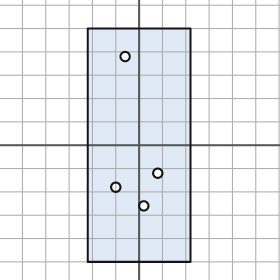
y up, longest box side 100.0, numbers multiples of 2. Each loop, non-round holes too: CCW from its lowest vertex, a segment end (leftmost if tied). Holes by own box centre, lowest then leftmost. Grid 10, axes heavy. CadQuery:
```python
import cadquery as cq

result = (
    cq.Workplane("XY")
    .moveTo(-22.0, -50.0)
    .lineTo(22.0, -50.0)
    .lineTo(22.0, 50.0)
    .lineTo(-22.0, 50.0)
    .close()
    .moveTo(2.0, -26.0)
    .circle(2.0)
    .moveTo(-10.0, -18.0)
    .circle(2.0)
    .moveTo(8.0, -12.0)
    .circle(2.0)
    .moveTo(-6.0, 38.0)
    .circle(2.0)
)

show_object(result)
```